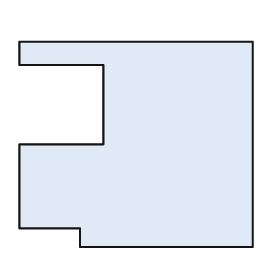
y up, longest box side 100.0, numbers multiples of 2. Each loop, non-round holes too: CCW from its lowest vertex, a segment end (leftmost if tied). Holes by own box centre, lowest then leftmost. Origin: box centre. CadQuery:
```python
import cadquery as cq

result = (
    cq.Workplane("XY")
    .moveTo(-24.0, -44.0)
    .lineTo(50.0, -44.0)
    .lineTo(50.0, 44.0)
    .lineTo(-50.0, 44.0)
    .lineTo(-50.0, 34.0)
    .lineTo(-14.0, 34.0)
    .lineTo(-14.0, 0.0)
    .lineTo(-50.0, 0.0)
    .lineTo(-50.0, -36.0)
    .lineTo(-24.0, -36.0)
    .close()
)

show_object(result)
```